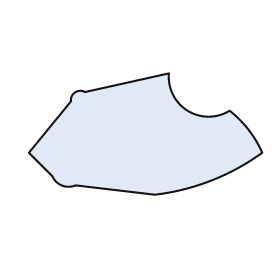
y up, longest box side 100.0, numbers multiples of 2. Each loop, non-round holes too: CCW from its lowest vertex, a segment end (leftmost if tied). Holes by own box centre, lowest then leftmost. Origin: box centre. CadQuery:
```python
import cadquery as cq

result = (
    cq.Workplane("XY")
    .moveTo(4.0, -26.0)
    .threePointArc((28.0, -20.0), (50.0, -8.0))
    .threePointArc((44.0, 2.0), (36.0, 10.0))
    .threePointArc((18.0, 10.0), (10.0, 26.0))
    .lineTo(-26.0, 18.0)
    .threePointArc((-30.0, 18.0), (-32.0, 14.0))
    .lineTo(-50.0, -8.0)
    .lineTo(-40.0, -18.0)
    .threePointArc((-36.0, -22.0), (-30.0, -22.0))
    .close()
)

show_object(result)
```